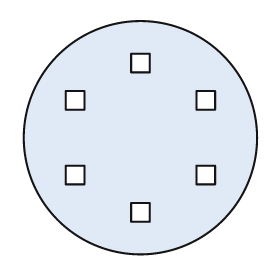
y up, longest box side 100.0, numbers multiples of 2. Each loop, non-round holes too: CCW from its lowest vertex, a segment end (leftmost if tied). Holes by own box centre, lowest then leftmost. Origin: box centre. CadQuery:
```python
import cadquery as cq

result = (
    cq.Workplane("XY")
    .moveTo(0.0, 0.0)
    .circle(50.0)
    .moveTo(-4.0, -36.0)
    .lineTo(4.0, -36.0)
    .lineTo(4.0, -28.0)
    .lineTo(-4.0, -28.0)
    .close()
    .moveTo(-32.0, -20.0)
    .lineTo(-24.0, -20.0)
    .lineTo(-24.0, -12.0)
    .lineTo(-32.0, -12.0)
    .close()
    .moveTo(24.0, -20.0)
    .lineTo(32.0, -20.0)
    .lineTo(32.0, -12.0)
    .lineTo(24.0, -12.0)
    .close()
    .moveTo(-32.0, 12.0)
    .lineTo(-24.0, 12.0)
    .lineTo(-24.0, 20.0)
    .lineTo(-32.0, 20.0)
    .close()
    .moveTo(24.0, 12.0)
    .lineTo(32.0, 12.0)
    .lineTo(32.0, 20.0)
    .lineTo(24.0, 20.0)
    .close()
    .moveTo(-4.0, 28.0)
    .lineTo(4.0, 28.0)
    .lineTo(4.0, 36.0)
    .lineTo(-4.0, 36.0)
    .close()
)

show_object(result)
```